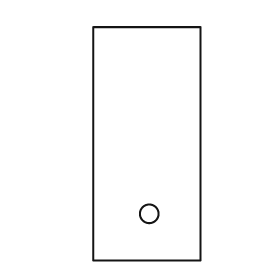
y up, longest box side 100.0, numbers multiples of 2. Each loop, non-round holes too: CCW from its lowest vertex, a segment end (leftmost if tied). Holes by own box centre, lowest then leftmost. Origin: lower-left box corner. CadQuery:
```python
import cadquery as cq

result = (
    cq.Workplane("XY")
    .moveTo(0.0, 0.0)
    .lineTo(46.0, 0.0)
    .lineTo(46.0, 100.0)
    .lineTo(0.0, 100.0)
    .close()
    .moveTo(24.0, 20.0)
    .circle(4.0)
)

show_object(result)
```